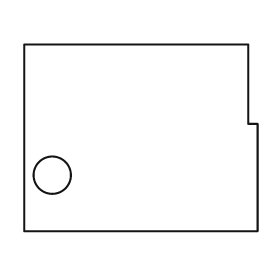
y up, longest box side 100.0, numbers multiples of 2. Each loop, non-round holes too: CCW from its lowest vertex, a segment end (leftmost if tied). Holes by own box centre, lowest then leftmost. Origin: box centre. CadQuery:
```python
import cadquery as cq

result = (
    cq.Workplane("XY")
    .moveTo(-50.0, -40.0)
    .lineTo(50.0, -40.0)
    .lineTo(50.0, 6.0)
    .lineTo(46.0, 6.0)
    .lineTo(46.0, 40.0)
    .lineTo(-50.0, 40.0)
    .close()
    .moveTo(-38.0, -16.0)
    .circle(8.0)
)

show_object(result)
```